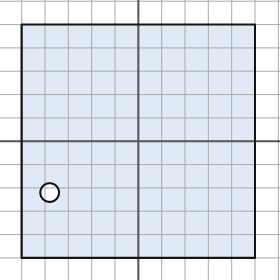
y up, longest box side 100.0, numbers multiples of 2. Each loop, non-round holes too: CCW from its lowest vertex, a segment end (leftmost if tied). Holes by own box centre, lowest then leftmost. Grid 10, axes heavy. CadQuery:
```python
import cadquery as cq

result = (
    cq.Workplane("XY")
    .moveTo(-50.0, -50.0)
    .lineTo(50.0, -50.0)
    .lineTo(50.0, 50.0)
    .lineTo(-50.0, 50.0)
    .close()
    .moveTo(-38.0, -22.0)
    .circle(4.0)
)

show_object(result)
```